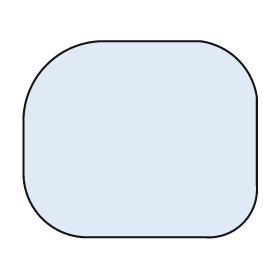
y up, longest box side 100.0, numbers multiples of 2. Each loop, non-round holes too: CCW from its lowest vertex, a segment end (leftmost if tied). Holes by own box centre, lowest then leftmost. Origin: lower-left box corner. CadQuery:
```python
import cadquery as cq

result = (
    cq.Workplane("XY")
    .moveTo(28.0, 0.0)
    .lineTo(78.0, 0.0)
    .threePointArc((94.0, 6.0), (100.0, 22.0))
    .lineTo(100.0, 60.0)
    .threePointArc((92.0, 76.0), (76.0, 84.0))
    .lineTo(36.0, 84.0)
    .threePointArc((10.0, 74.0), (0.0, 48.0))
    .lineTo(0.0, 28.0)
    .threePointArc((8.0, 8.0), (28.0, 0.0))
    .close()
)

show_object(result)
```